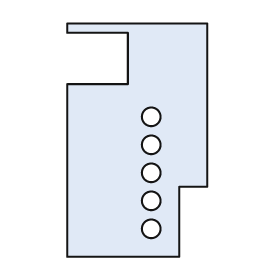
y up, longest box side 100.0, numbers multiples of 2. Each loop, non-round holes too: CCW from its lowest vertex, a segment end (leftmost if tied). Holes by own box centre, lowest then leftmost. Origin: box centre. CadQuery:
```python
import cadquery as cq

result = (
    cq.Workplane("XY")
    .moveTo(-30.0, -50.0)
    .lineTo(18.0, -50.0)
    .lineTo(18.0, -20.0)
    .lineTo(30.0, -20.0)
    .lineTo(30.0, 50.0)
    .lineTo(-30.0, 50.0)
    .lineTo(-30.0, 46.0)
    .lineTo(-4.0, 46.0)
    .lineTo(-4.0, 24.0)
    .lineTo(-30.0, 24.0)
    .close()
    .moveTo(6.0, -38.0)
    .circle(4.0)
    .moveTo(6.0, -26.0)
    .circle(4.0)
    .moveTo(6.0, -14.0)
    .circle(4.0)
    .moveTo(6.0, -2.0)
    .circle(4.0)
    .moveTo(6.0, 10.0)
    .circle(4.0)
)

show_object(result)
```